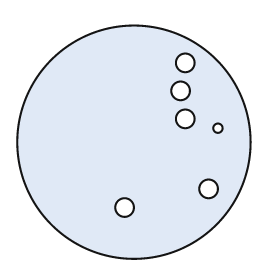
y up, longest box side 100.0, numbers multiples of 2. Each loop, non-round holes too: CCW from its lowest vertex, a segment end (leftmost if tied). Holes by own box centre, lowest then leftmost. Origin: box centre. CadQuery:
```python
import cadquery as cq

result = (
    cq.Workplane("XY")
    .moveTo(0.0, 0.0)
    .circle(50.0)
    .moveTo(-4.0, -28.0)
    .circle(4.0)
    .moveTo(32.0, -20.0)
    .circle(4.0)
    .moveTo(36.0, 6.0)
    .circle(2.0)
    .moveTo(22.0, 10.0)
    .circle(4.0)
    .moveTo(20.0, 22.0)
    .circle(4.0)
    .moveTo(22.0, 34.0)
    .circle(4.0)
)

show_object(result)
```